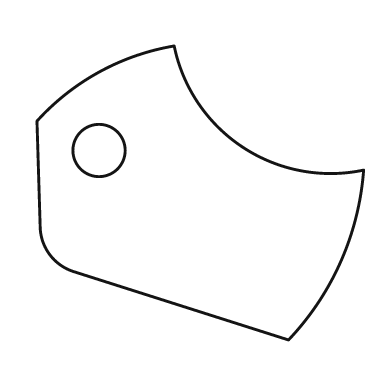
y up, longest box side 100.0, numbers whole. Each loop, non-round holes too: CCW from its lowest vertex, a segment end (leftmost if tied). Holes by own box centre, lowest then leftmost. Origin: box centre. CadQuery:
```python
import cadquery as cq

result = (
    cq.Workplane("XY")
    .moveTo(27.0, -45.0)
    .threePointArc((43.0, -21.0), (50.0, 7.0))
    .threePointArc((13.0, 14.0), (-8.0, 45.0))
    .threePointArc((-31.0, 37.0), (-50.0, 22.0))
    .lineTo(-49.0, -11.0)
    .threePointArc((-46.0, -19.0), (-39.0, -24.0))
    .close()
    .moveTo(-31.0, 13.0)
    .circle(8.0)
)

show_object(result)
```